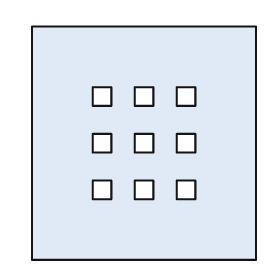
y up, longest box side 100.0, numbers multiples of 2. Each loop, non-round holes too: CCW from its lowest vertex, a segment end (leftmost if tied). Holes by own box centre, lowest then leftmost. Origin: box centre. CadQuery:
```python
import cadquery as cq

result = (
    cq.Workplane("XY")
    .moveTo(-48.0, -50.0)
    .lineTo(48.0, -50.0)
    .lineTo(48.0, 50.0)
    .lineTo(-48.0, 50.0)
    .close()
    .moveTo(-22.0, -24.0)
    .lineTo(-14.0, -24.0)
    .lineTo(-14.0, -16.0)
    .lineTo(-22.0, -16.0)
    .close()
    .moveTo(-4.0, -24.0)
    .lineTo(4.0, -24.0)
    .lineTo(4.0, -16.0)
    .lineTo(-4.0, -16.0)
    .close()
    .moveTo(14.0, -24.0)
    .lineTo(22.0, -24.0)
    .lineTo(22.0, -16.0)
    .lineTo(14.0, -16.0)
    .close()
    .moveTo(-22.0, -4.0)
    .lineTo(-14.0, -4.0)
    .lineTo(-14.0, 4.0)
    .lineTo(-22.0, 4.0)
    .close()
    .moveTo(-4.0, -4.0)
    .lineTo(4.0, -4.0)
    .lineTo(4.0, 4.0)
    .lineTo(-4.0, 4.0)
    .close()
    .moveTo(14.0, -4.0)
    .lineTo(22.0, -4.0)
    .lineTo(22.0, 4.0)
    .lineTo(14.0, 4.0)
    .close()
    .moveTo(-22.0, 16.0)
    .lineTo(-14.0, 16.0)
    .lineTo(-14.0, 24.0)
    .lineTo(-22.0, 24.0)
    .close()
    .moveTo(-4.0, 16.0)
    .lineTo(4.0, 16.0)
    .lineTo(4.0, 24.0)
    .lineTo(-4.0, 24.0)
    .close()
    .moveTo(14.0, 16.0)
    .lineTo(22.0, 16.0)
    .lineTo(22.0, 24.0)
    .lineTo(14.0, 24.0)
    .close()
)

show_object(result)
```